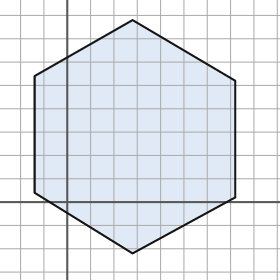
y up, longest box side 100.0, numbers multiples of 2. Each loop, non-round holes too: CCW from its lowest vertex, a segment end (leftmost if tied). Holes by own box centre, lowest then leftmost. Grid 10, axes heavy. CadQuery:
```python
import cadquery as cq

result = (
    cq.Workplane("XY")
    .moveTo(28.0, -22.0)
    .lineTo(72.0, 2.0)
    .lineTo(72.0, 52.0)
    .lineTo(28.0, 78.0)
    .lineTo(-14.0, 54.0)
    .lineTo(-14.0, 4.0)
    .close()
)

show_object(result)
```